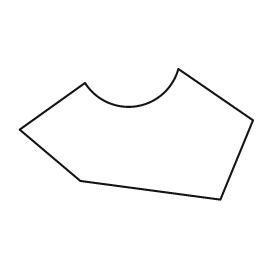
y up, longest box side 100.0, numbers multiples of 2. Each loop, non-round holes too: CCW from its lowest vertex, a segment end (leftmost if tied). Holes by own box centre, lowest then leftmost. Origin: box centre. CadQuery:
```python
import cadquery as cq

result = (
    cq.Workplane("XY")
    .moveTo(36.0, -28.0)
    .lineTo(50.0, 6.0)
    .lineTo(18.0, 28.0)
    .threePointArc((0.0, 12.0), (-22.0, 22.0))
    .lineTo(-50.0, 2.0)
    .lineTo(-24.0, -20.0)
    .close()
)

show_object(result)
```